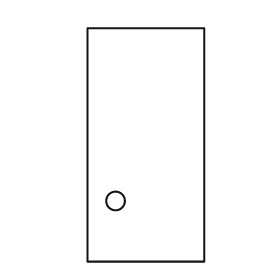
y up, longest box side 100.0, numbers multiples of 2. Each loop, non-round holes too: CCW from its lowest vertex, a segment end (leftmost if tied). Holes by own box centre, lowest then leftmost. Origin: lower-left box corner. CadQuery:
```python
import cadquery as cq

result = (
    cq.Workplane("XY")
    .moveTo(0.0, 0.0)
    .lineTo(50.0, 0.0)
    .lineTo(50.0, 100.0)
    .lineTo(0.0, 100.0)
    .close()
    .moveTo(12.0, 26.0)
    .circle(4.0)
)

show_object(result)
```